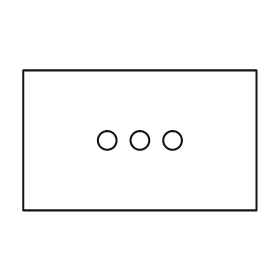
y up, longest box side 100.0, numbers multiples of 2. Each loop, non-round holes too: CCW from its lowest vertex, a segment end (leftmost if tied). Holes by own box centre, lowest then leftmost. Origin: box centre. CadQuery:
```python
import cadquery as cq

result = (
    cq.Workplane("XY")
    .moveTo(-50.0, -30.0)
    .lineTo(50.0, -30.0)
    .lineTo(50.0, 30.0)
    .lineTo(-50.0, 30.0)
    .close()
    .moveTo(-14.0, 0.0)
    .circle(4.0)
    .moveTo(0.0, 0.0)
    .circle(4.0)
    .moveTo(14.0, 0.0)
    .circle(4.0)
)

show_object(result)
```